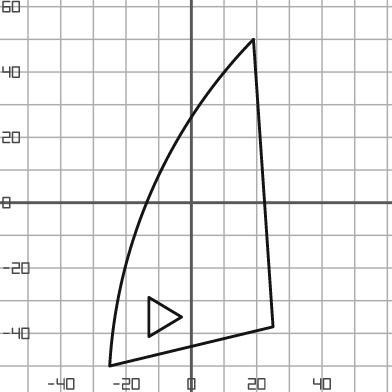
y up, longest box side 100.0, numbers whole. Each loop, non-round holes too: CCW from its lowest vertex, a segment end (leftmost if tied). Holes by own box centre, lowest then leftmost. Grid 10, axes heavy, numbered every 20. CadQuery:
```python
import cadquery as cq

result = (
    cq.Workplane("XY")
    .moveTo(-25.0, -50.0)
    .lineTo(25.0, -38.0)
    .lineTo(19.0, 50.0)
    .threePointArc((-12.0, 4.0), (-25.0, -50.0))
    .close()
    .moveTo(-13.0, -41.0)
    .lineTo(-3.0, -35.0)
    .lineTo(-13.0, -29.0)
    .close()
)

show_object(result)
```